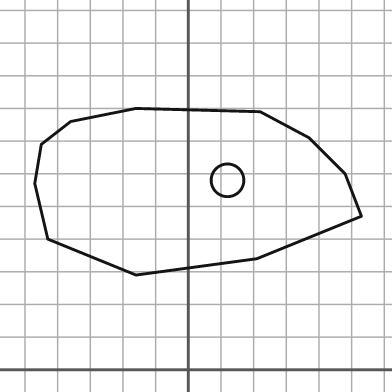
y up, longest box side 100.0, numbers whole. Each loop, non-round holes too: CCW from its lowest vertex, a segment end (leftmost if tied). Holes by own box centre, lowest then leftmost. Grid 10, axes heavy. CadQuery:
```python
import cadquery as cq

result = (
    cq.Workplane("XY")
    .moveTo(-16.0, 29.0)
    .lineTo(21.0, 34.0)
    .lineTo(53.0, 47.0)
    .lineTo(48.0, 60.0)
    .lineTo(37.0, 71.0)
    .lineTo(22.0, 79.0)
    .lineTo(-16.0, 80.0)
    .lineTo(-36.0, 76.0)
    .lineTo(-45.0, 69.0)
    .lineTo(-47.0, 57.0)
    .lineTo(-43.0, 40.0)
    .close()
    .moveTo(12.0, 58.0)
    .circle(5.0)
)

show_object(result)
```